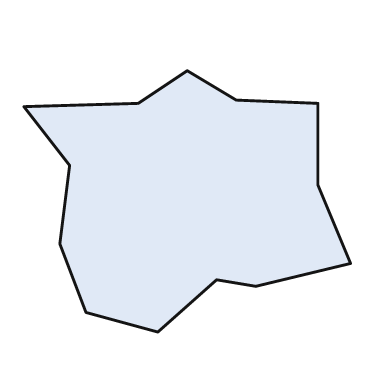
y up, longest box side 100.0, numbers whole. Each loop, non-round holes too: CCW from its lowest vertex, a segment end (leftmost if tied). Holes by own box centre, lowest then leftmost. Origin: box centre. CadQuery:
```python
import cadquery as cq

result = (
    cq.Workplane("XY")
    .moveTo(-9.0, -40.0)
    .lineTo(9.0, -24.0)
    .lineTo(21.0, -26.0)
    .lineTo(50.0, -19.0)
    .lineTo(40.0, 5.0)
    .lineTo(40.0, 30.0)
    .lineTo(15.0, 31.0)
    .lineTo(0.0, 40.0)
    .lineTo(-15.0, 30.0)
    .lineTo(-50.0, 29.0)
    .lineTo(-36.0, 11.0)
    .lineTo(-39.0, -13.0)
    .lineTo(-31.0, -34.0)
    .close()
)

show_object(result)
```